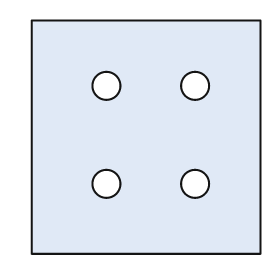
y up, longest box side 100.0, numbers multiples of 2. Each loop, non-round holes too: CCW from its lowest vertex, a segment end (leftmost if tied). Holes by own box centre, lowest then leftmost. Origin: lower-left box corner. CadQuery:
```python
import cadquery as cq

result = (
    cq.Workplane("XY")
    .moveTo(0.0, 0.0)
    .lineTo(98.0, 0.0)
    .lineTo(98.0, 100.0)
    .lineTo(0.0, 100.0)
    .close()
    .moveTo(32.0, 30.0)
    .circle(6.0)
    .moveTo(70.0, 30.0)
    .circle(6.0)
    .moveTo(32.0, 72.0)
    .circle(6.0)
    .moveTo(70.0, 72.0)
    .circle(6.0)
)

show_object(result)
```